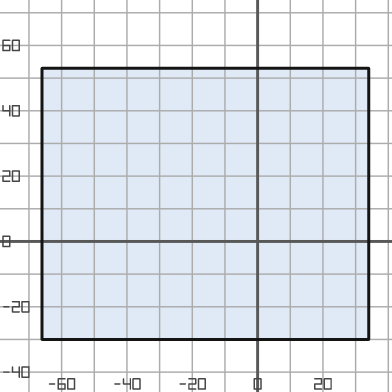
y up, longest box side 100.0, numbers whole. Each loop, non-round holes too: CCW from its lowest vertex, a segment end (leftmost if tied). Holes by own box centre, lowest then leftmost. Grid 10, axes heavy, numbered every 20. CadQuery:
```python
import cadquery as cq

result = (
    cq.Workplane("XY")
    .moveTo(-66.0, -30.0)
    .lineTo(34.0, -30.0)
    .lineTo(34.0, 53.0)
    .lineTo(-66.0, 53.0)
    .close()
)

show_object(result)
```